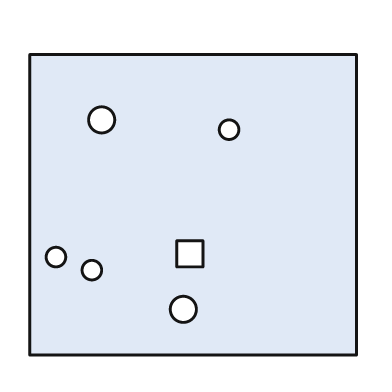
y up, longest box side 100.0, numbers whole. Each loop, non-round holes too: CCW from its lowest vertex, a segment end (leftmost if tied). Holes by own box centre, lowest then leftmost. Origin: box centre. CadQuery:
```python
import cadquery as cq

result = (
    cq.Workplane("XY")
    .moveTo(-50.0, -46.0)
    .lineTo(50.0, -46.0)
    .lineTo(50.0, 46.0)
    .lineTo(-50.0, 46.0)
    .close()
    .moveTo(-3.0, -32.0)
    .circle(4.0)
    .moveTo(-31.0, -20.0)
    .circle(3.0)
    .moveTo(-42.0, -16.0)
    .circle(3.0)
    .moveTo(-5.0, -19.0)
    .lineTo(3.0, -19.0)
    .lineTo(3.0, -11.0)
    .lineTo(-5.0, -11.0)
    .close()
    .moveTo(11.0, 23.0)
    .circle(3.0)
    .moveTo(-28.0, 26.0)
    .circle(4.0)
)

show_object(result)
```